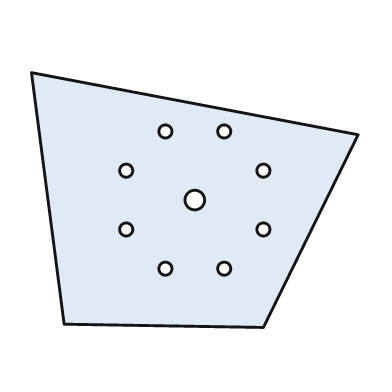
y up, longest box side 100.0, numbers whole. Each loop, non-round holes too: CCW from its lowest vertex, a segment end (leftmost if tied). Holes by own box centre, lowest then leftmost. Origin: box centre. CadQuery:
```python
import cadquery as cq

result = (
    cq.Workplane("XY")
    .moveTo(21.0, -39.0)
    .lineTo(50.0, 20.0)
    .lineTo(-50.0, 39.0)
    .lineTo(-40.0, -38.0)
    .close()
    .moveTo(-9.0, -21.0)
    .circle(2.0)
    .moveTo(9.0, -21.0)
    .circle(2.0)
    .moveTo(-21.0, -9.0)
    .circle(2.0)
    .moveTo(21.0, -9.0)
    .circle(2.0)
    .moveTo(0.0, 0.0)
    .circle(3.0)
    .moveTo(-21.0, 9.0)
    .circle(2.0)
    .moveTo(21.0, 9.0)
    .circle(2.0)
    .moveTo(-9.0, 21.0)
    .circle(2.0)
    .moveTo(9.0, 21.0)
    .circle(2.0)
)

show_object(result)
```